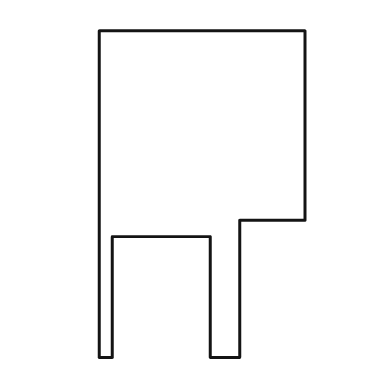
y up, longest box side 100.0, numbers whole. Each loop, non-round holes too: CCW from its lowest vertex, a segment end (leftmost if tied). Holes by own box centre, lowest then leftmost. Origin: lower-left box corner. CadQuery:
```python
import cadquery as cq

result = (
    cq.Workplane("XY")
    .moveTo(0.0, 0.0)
    .lineTo(4.0, 0.0)
    .lineTo(4.0, 37.0)
    .lineTo(34.0, 37.0)
    .lineTo(34.0, 0.0)
    .lineTo(43.0, 0.0)
    .lineTo(43.0, 42.0)
    .lineTo(63.0, 42.0)
    .lineTo(63.0, 100.0)
    .lineTo(0.0, 100.0)
    .close()
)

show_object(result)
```